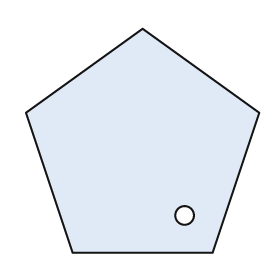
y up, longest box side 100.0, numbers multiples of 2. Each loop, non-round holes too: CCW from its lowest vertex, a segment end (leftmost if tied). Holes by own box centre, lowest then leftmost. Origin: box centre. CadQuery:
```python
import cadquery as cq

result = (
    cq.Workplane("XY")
    .moveTo(-30.0, -48.0)
    .lineTo(30.0, -48.0)
    .lineTo(50.0, 12.0)
    .lineTo(0.0, 48.0)
    .lineTo(-50.0, 12.0)
    .close()
    .moveTo(18.0, -32.0)
    .circle(4.0)
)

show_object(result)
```